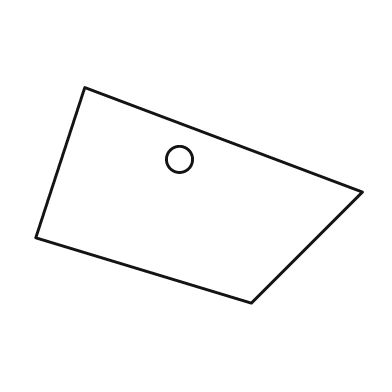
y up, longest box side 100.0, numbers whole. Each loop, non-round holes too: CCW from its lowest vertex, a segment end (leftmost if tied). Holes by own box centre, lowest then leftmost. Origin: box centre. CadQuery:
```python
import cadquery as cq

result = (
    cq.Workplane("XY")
    .moveTo(16.0, -33.0)
    .lineTo(50.0, 1.0)
    .lineTo(-35.0, 33.0)
    .lineTo(-50.0, -13.0)
    .close()
    .moveTo(-6.0, 11.0)
    .circle(4.0)
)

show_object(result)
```